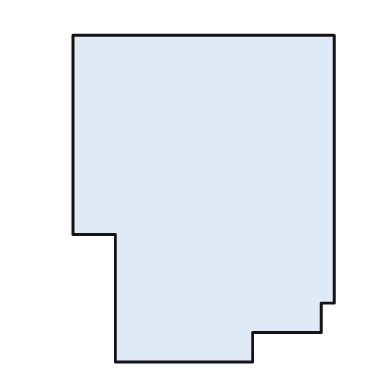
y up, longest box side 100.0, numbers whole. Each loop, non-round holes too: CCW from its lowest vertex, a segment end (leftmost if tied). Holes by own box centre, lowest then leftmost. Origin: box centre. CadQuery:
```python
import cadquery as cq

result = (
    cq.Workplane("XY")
    .moveTo(-27.0, -50.0)
    .lineTo(15.0, -50.0)
    .lineTo(15.0, -41.0)
    .lineTo(36.0, -41.0)
    .lineTo(36.0, -32.0)
    .lineTo(40.0, -32.0)
    .lineTo(40.0, 50.0)
    .lineTo(-40.0, 50.0)
    .lineTo(-40.0, -11.0)
    .lineTo(-27.0, -11.0)
    .close()
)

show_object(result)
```